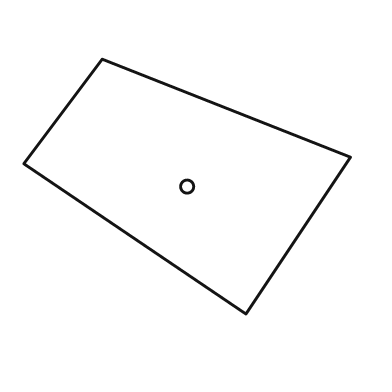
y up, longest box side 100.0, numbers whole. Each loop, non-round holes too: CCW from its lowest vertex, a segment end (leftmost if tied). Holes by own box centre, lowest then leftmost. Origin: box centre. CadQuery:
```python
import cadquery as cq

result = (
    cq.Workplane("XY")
    .moveTo(18.0, -39.0)
    .lineTo(50.0, 9.0)
    .lineTo(-26.0, 39.0)
    .lineTo(-50.0, 7.0)
    .close()
    .moveTo(0.0, 0.0)
    .circle(2.0)
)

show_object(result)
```